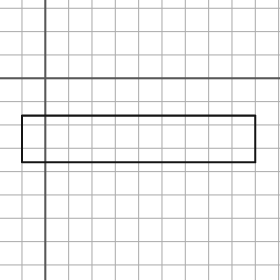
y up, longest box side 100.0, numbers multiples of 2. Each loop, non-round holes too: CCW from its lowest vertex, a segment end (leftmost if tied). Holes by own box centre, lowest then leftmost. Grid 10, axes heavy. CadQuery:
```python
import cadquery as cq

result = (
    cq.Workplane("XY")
    .moveTo(-10.0, -36.0)
    .lineTo(90.0, -36.0)
    .lineTo(90.0, -16.0)
    .lineTo(-10.0, -16.0)
    .close()
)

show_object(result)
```